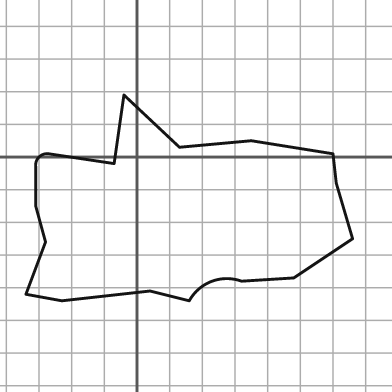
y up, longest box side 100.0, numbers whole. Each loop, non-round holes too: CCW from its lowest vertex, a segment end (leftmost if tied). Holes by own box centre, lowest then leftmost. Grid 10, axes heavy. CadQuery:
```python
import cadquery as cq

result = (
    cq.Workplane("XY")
    .moveTo(-23.0, -44.0)
    .lineTo(4.0, -41.0)
    .lineTo(16.0, -44.0)
    .threePointArc((23.0, -38.0), (32.0, -38.0))
    .lineTo(48.0, -37.0)
    .lineTo(66.0, -25.0)
    .lineTo(61.0, -8.0)
    .lineTo(60.0, 1.0)
    .lineTo(35.0, 5.0)
    .lineTo(13.0, 3.0)
    .lineTo(-4.0, 19.0)
    .lineTo(-7.0, -2.0)
    .lineTo(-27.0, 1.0)
    .threePointArc((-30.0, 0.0), (-31.0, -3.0))
    .lineTo(-31.0, -15.0)
    .lineTo(-28.0, -26.0)
    .lineTo(-34.0, -42.0)
    .close()
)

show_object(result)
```